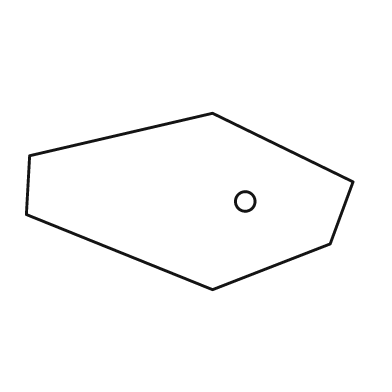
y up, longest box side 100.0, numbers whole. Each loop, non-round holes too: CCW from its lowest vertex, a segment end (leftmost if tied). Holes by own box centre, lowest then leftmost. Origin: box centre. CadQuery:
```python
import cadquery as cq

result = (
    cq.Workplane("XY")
    .moveTo(7.0, -27.0)
    .lineTo(43.0, -13.0)
    .lineTo(50.0, 6.0)
    .lineTo(7.0, 27.0)
    .lineTo(-49.0, 14.0)
    .lineTo(-50.0, -4.0)
    .close()
    .moveTo(17.0, 0.0)
    .circle(3.0)
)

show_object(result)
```